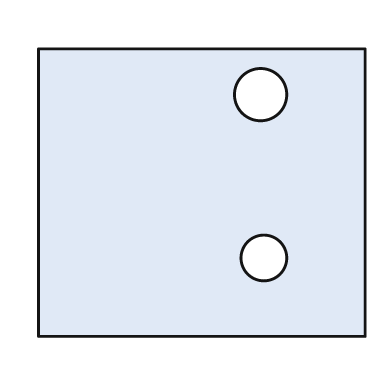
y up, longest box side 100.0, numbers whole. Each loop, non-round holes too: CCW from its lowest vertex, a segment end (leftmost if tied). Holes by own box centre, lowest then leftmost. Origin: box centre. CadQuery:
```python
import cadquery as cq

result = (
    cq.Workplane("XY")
    .moveTo(-50.0, -44.0)
    .lineTo(50.0, -44.0)
    .lineTo(50.0, 44.0)
    .lineTo(-50.0, 44.0)
    .close()
    .moveTo(19.0, -20.0)
    .circle(7.0)
    .moveTo(18.0, 30.0)
    .circle(8.0)
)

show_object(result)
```